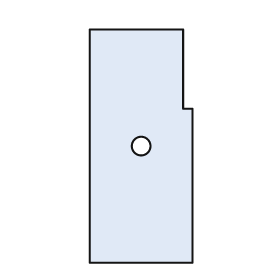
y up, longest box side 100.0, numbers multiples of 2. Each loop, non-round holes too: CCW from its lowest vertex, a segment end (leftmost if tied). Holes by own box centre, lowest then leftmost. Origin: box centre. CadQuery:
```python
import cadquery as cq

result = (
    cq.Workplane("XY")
    .moveTo(-22.0, -50.0)
    .lineTo(22.0, -50.0)
    .lineTo(22.0, 16.0)
    .lineTo(18.0, 16.0)
    .lineTo(18.0, 50.0)
    .lineTo(-22.0, 50.0)
    .close()
    .moveTo(0.0, 0.0)
    .circle(4.0)
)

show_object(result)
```